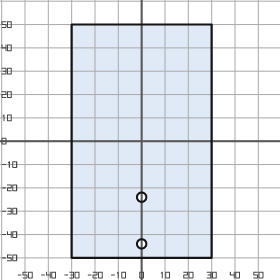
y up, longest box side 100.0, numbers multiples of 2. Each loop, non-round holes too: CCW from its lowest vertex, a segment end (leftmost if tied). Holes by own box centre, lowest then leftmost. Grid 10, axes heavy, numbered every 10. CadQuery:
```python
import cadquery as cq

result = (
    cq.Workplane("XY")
    .moveTo(-30.0, -50.0)
    .lineTo(30.0, -50.0)
    .lineTo(30.0, 50.0)
    .lineTo(-30.0, 50.0)
    .close()
    .moveTo(0.0, -44.0)
    .circle(2.0)
    .moveTo(0.0, -24.0)
    .circle(2.0)
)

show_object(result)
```